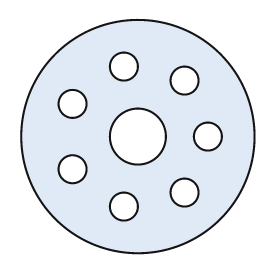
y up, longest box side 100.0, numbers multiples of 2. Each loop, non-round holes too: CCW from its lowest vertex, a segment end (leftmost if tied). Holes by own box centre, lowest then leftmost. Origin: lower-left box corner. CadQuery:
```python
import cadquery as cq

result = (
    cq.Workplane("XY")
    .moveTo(50.0, 50.0)
    .circle(50.0)
    .moveTo(44.0, 20.0)
    .circle(6.0)
    .moveTo(70.0, 26.0)
    .circle(6.0)
    .moveTo(22.0, 36.0)
    .circle(6.0)
    .moveTo(50.0, 50.0)
    .circle(12.0)
    .moveTo(80.0, 50.0)
    .circle(6.0)
    .moveTo(22.0, 64.0)
    .circle(6.0)
    .moveTo(70.0, 74.0)
    .circle(6.0)
    .moveTo(44.0, 80.0)
    .circle(6.0)
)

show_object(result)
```